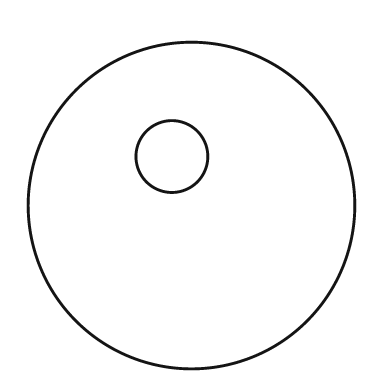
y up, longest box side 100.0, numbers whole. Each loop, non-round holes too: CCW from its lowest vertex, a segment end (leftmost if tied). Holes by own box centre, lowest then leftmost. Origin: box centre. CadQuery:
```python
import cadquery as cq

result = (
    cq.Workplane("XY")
    .moveTo(0.0, 0.0)
    .circle(50.0)
    .moveTo(-6.0, 15.0)
    .circle(11.0)
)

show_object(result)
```